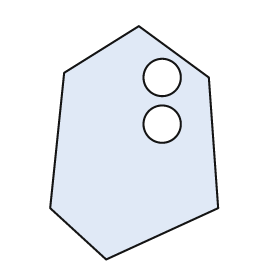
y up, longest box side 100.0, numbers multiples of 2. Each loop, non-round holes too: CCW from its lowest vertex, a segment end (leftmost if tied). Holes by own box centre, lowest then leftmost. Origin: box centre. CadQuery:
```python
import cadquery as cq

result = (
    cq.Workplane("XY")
    .moveTo(-12.0, -50.0)
    .lineTo(36.0, -28.0)
    .lineTo(32.0, 28.0)
    .lineTo(2.0, 50.0)
    .lineTo(-30.0, 30.0)
    .lineTo(-36.0, -28.0)
    .close()
    .moveTo(12.0, 8.0)
    .circle(8.0)
    .moveTo(12.0, 28.0)
    .circle(8.0)
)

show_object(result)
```